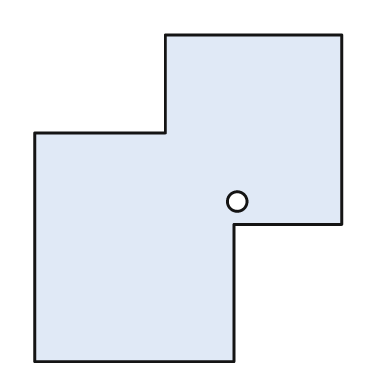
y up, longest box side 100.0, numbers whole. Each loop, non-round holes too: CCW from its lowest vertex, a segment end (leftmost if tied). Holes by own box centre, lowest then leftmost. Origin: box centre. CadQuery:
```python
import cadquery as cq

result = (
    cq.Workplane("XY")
    .moveTo(-47.0, -50.0)
    .lineTo(14.0, -50.0)
    .lineTo(14.0, -8.0)
    .lineTo(47.0, -8.0)
    .lineTo(47.0, 50.0)
    .lineTo(-7.0, 50.0)
    .lineTo(-7.0, 20.0)
    .lineTo(-47.0, 20.0)
    .close()
    .moveTo(15.0, -1.0)
    .circle(3.0)
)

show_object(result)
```